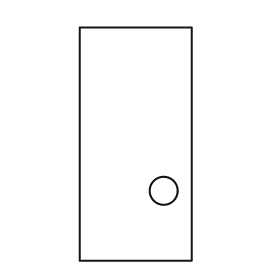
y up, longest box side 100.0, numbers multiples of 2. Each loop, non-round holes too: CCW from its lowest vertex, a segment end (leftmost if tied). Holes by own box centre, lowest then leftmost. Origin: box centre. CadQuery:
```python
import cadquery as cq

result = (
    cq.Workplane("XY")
    .moveTo(-24.0, -50.0)
    .lineTo(24.0, -50.0)
    .lineTo(24.0, 50.0)
    .lineTo(-24.0, 50.0)
    .close()
    .moveTo(12.0, -20.0)
    .circle(6.0)
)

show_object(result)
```